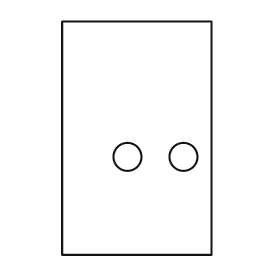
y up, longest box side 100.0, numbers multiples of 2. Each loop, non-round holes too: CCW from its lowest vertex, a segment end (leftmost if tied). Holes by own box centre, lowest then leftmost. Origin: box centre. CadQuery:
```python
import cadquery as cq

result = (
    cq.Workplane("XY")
    .moveTo(-32.0, -50.0)
    .lineTo(32.0, -50.0)
    .lineTo(32.0, 50.0)
    .lineTo(-32.0, 50.0)
    .close()
    .moveTo(-4.0, -8.0)
    .circle(6.0)
    .moveTo(20.0, -8.0)
    .circle(6.0)
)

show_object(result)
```